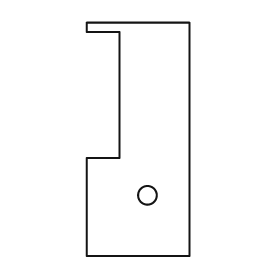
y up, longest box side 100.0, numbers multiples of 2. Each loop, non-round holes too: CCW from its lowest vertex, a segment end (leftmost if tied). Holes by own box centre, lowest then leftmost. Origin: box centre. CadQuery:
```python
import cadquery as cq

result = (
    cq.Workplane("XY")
    .moveTo(-22.0, -50.0)
    .lineTo(22.0, -50.0)
    .lineTo(22.0, 50.0)
    .lineTo(-22.0, 50.0)
    .lineTo(-22.0, 46.0)
    .lineTo(-8.0, 46.0)
    .lineTo(-8.0, -8.0)
    .lineTo(-22.0, -8.0)
    .close()
    .moveTo(4.0, -24.0)
    .circle(4.0)
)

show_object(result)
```